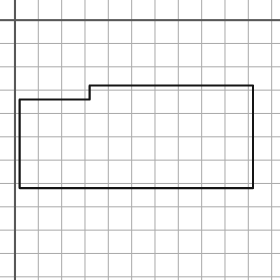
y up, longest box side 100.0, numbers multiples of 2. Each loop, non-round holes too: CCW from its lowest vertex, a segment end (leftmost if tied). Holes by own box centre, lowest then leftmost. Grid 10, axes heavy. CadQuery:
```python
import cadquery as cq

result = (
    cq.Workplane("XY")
    .moveTo(2.0, -72.0)
    .lineTo(102.0, -72.0)
    .lineTo(102.0, -28.0)
    .lineTo(32.0, -28.0)
    .lineTo(32.0, -34.0)
    .lineTo(2.0, -34.0)
    .close()
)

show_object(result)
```